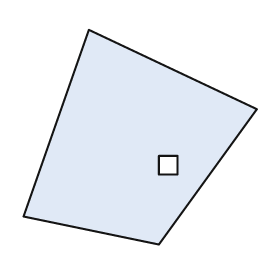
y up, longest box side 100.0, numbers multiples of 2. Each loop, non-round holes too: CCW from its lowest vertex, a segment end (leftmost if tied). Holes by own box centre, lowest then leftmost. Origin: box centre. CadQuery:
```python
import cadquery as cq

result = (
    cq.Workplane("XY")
    .moveTo(8.0, -46.0)
    .lineTo(50.0, 12.0)
    .lineTo(-22.0, 46.0)
    .lineTo(-50.0, -34.0)
    .close()
    .moveTo(8.0, -16.0)
    .lineTo(16.0, -16.0)
    .lineTo(16.0, -8.0)
    .lineTo(8.0, -8.0)
    .close()
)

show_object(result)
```